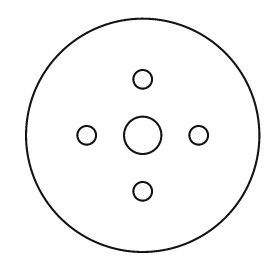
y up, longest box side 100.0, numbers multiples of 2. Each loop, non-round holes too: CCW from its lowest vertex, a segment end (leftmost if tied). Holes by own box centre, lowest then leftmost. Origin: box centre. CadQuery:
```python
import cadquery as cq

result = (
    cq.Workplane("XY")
    .moveTo(0.0, 0.0)
    .circle(50.0)
    .moveTo(0.0, -24.0)
    .circle(4.0)
    .moveTo(-24.0, 0.0)
    .circle(4.0)
    .moveTo(0.0, 0.0)
    .circle(8.0)
    .moveTo(24.0, 0.0)
    .circle(4.0)
    .moveTo(0.0, 24.0)
    .circle(4.0)
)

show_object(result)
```